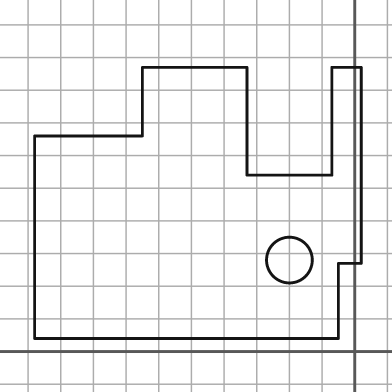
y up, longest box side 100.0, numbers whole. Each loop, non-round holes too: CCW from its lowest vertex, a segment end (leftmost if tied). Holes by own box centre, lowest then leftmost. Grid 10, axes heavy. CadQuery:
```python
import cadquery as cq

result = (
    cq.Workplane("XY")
    .moveTo(-98.0, 4.0)
    .lineTo(-5.0, 4.0)
    .lineTo(-5.0, 27.0)
    .lineTo(2.0, 27.0)
    .lineTo(2.0, 87.0)
    .lineTo(-7.0, 87.0)
    .lineTo(-7.0, 54.0)
    .lineTo(-33.0, 54.0)
    .lineTo(-33.0, 87.0)
    .lineTo(-65.0, 87.0)
    .lineTo(-65.0, 66.0)
    .lineTo(-98.0, 66.0)
    .close()
    .moveTo(-20.0, 28.0)
    .circle(7.0)
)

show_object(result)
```